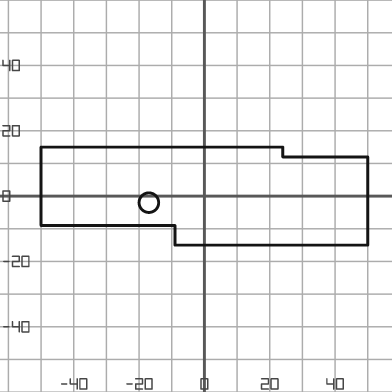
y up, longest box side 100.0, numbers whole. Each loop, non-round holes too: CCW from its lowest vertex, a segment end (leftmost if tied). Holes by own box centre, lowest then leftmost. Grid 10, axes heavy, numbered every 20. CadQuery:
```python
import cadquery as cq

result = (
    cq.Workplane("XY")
    .moveTo(-9.0, -15.0)
    .lineTo(50.0, -15.0)
    .lineTo(50.0, 12.0)
    .lineTo(24.0, 12.0)
    .lineTo(24.0, 15.0)
    .lineTo(-50.0, 15.0)
    .lineTo(-50.0, -9.0)
    .lineTo(-9.0, -9.0)
    .close()
    .moveTo(-17.0, -2.0)
    .circle(3.0)
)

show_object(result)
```